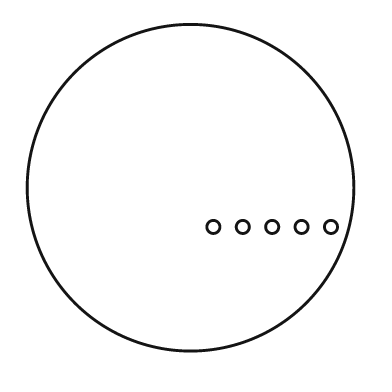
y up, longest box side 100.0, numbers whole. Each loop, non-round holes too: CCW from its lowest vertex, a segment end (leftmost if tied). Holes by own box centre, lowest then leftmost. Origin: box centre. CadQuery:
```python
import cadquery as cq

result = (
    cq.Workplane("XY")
    .moveTo(0.0, 0.0)
    .circle(50.0)
    .moveTo(7.0, -12.0)
    .circle(2.0)
    .moveTo(16.0, -12.0)
    .circle(2.0)
    .moveTo(25.0, -12.0)
    .circle(2.0)
    .moveTo(34.0, -12.0)
    .circle(2.0)
    .moveTo(43.0, -12.0)
    .circle(2.0)
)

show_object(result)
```